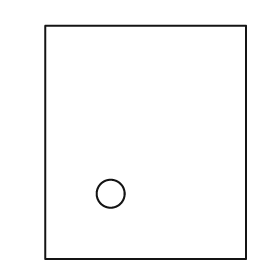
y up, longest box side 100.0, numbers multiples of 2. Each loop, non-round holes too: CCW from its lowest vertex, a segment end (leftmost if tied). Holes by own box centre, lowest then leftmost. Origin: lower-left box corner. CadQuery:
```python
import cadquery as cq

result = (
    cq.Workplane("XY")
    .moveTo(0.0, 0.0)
    .lineTo(86.0, 0.0)
    .lineTo(86.0, 100.0)
    .lineTo(0.0, 100.0)
    .close()
    .moveTo(28.0, 28.0)
    .circle(6.0)
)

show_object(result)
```